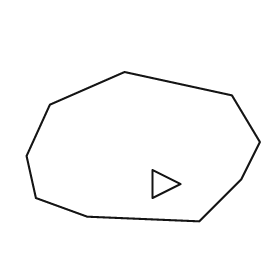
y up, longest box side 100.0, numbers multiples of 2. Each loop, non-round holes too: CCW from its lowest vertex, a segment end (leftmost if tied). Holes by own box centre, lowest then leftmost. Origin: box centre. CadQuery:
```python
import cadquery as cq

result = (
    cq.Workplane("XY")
    .moveTo(24.0, -32.0)
    .lineTo(42.0, -14.0)
    .lineTo(50.0, 2.0)
    .lineTo(38.0, 22.0)
    .lineTo(-8.0, 32.0)
    .lineTo(-40.0, 18.0)
    .lineTo(-50.0, -4.0)
    .lineTo(-46.0, -22.0)
    .lineTo(-24.0, -30.0)
    .close()
    .moveTo(4.0, -22.0)
    .lineTo(16.0, -16.0)
    .lineTo(4.0, -10.0)
    .close()
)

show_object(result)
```